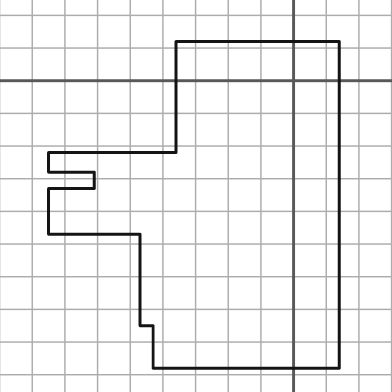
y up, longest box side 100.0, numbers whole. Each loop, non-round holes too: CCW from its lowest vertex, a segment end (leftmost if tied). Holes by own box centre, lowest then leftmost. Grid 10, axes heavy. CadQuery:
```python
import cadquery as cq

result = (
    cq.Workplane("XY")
    .moveTo(-43.0, -88.0)
    .lineTo(14.0, -88.0)
    .lineTo(14.0, 12.0)
    .lineTo(-36.0, 12.0)
    .lineTo(-36.0, -22.0)
    .lineTo(-75.0, -22.0)
    .lineTo(-75.0, -28.0)
    .lineTo(-61.0, -28.0)
    .lineTo(-61.0, -33.0)
    .lineTo(-75.0, -33.0)
    .lineTo(-75.0, -47.0)
    .lineTo(-47.0, -47.0)
    .lineTo(-47.0, -75.0)
    .lineTo(-43.0, -75.0)
    .close()
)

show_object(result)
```